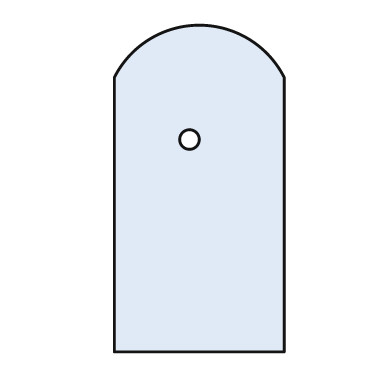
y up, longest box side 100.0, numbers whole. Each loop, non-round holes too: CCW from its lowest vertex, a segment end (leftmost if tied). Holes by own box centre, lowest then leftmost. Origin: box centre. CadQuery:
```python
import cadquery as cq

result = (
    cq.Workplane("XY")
    .moveTo(-26.0, -50.0)
    .lineTo(26.0, -50.0)
    .lineTo(26.0, 34.0)
    .threePointArc((0.0, 50.0), (-26.0, 34.0))
    .close()
    .moveTo(-3.0, 15.0)
    .circle(3.0)
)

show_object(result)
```